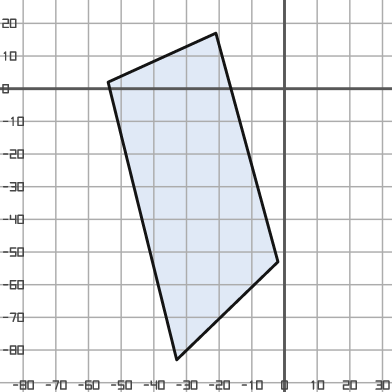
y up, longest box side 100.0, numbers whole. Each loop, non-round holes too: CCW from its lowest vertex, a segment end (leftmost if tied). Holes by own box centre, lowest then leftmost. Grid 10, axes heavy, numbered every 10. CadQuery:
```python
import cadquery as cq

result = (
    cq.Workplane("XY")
    .moveTo(-33.0, -83.0)
    .lineTo(-2.0, -53.0)
    .lineTo(-21.0, 17.0)
    .lineTo(-54.0, 2.0)
    .close()
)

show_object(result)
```